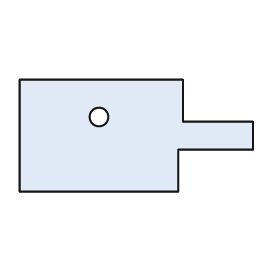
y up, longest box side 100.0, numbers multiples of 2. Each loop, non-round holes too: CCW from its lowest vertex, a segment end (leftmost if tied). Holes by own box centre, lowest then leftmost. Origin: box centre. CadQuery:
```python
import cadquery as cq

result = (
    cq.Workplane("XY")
    .moveTo(-50.0, -24.0)
    .lineTo(18.0, -24.0)
    .lineTo(18.0, -6.0)
    .lineTo(50.0, -6.0)
    .lineTo(50.0, 6.0)
    .lineTo(20.0, 6.0)
    .lineTo(20.0, 24.0)
    .lineTo(-50.0, 24.0)
    .close()
    .moveTo(-16.0, 8.0)
    .circle(4.0)
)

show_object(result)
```